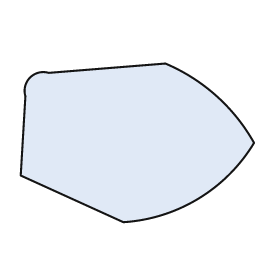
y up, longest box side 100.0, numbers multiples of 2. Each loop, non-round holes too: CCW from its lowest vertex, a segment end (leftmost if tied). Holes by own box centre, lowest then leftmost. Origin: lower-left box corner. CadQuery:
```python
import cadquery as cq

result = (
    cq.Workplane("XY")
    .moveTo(44.0, 0.0)
    .threePointArc((76.0, 10.0), (100.0, 34.0))
    .threePointArc((84.0, 54.0), (62.0, 68.0))
    .lineTo(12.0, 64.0)
    .threePointArc((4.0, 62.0), (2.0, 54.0))
    .lineTo(0.0, 20.0)
    .close()
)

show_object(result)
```